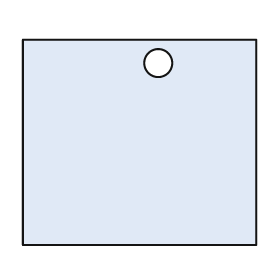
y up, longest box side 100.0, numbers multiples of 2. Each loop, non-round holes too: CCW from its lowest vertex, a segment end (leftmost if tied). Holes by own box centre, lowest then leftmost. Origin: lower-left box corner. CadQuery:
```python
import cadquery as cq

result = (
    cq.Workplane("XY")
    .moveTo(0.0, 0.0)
    .lineTo(100.0, 0.0)
    .lineTo(100.0, 88.0)
    .lineTo(0.0, 88.0)
    .close()
    .moveTo(58.0, 78.0)
    .circle(6.0)
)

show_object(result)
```